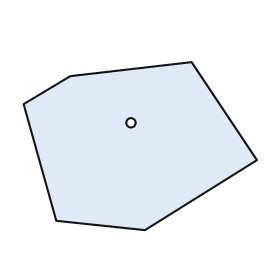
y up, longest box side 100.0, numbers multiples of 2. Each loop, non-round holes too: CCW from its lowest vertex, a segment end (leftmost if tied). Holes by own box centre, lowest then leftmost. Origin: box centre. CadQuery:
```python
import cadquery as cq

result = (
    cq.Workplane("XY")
    .moveTo(2.0, -36.0)
    .lineTo(50.0, -6.0)
    .lineTo(22.0, 36.0)
    .lineTo(-30.0, 30.0)
    .lineTo(-50.0, 18.0)
    .lineTo(-36.0, -32.0)
    .close()
    .moveTo(-4.0, 10.0)
    .circle(2.0)
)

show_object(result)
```